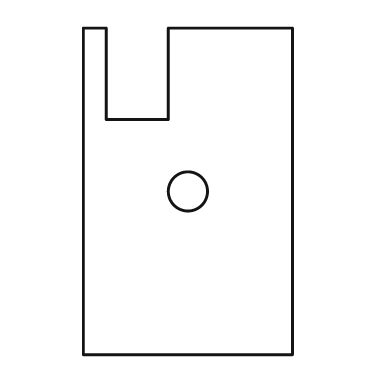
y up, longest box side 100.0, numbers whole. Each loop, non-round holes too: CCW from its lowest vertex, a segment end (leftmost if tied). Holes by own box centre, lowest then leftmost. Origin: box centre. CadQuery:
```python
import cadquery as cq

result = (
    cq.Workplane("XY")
    .moveTo(-32.0, -50.0)
    .lineTo(32.0, -50.0)
    .lineTo(32.0, 50.0)
    .lineTo(-6.0, 50.0)
    .lineTo(-6.0, 22.0)
    .lineTo(-25.0, 22.0)
    .lineTo(-25.0, 50.0)
    .lineTo(-32.0, 50.0)
    .close()
    .moveTo(0.0, 0.0)
    .circle(6.0)
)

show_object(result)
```